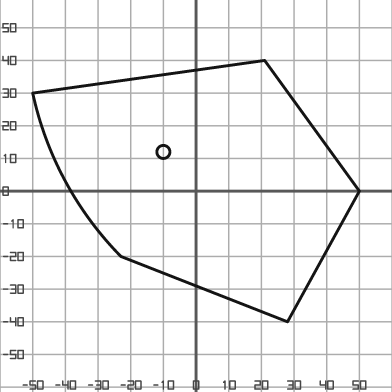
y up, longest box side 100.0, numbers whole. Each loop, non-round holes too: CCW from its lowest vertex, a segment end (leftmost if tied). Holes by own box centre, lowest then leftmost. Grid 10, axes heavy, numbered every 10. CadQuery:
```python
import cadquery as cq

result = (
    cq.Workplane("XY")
    .moveTo(28.0, -40.0)
    .lineTo(50.0, 0.0)
    .lineTo(21.0, 40.0)
    .lineTo(-50.0, 30.0)
    .threePointArc((-40.0, 3.0), (-23.0, -20.0))
    .close()
    .moveTo(-10.0, 12.0)
    .circle(2.0)
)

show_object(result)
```